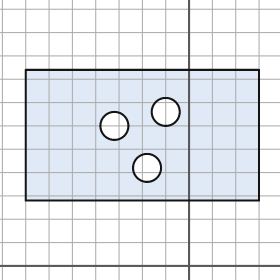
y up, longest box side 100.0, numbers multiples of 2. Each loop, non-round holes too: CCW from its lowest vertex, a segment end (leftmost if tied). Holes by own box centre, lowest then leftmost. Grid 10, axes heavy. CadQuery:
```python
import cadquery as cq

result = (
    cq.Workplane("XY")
    .moveTo(-70.0, 28.0)
    .lineTo(30.0, 28.0)
    .lineTo(30.0, 84.0)
    .lineTo(-70.0, 84.0)
    .close()
    .moveTo(-18.0, 42.0)
    .circle(6.0)
    .moveTo(-32.0, 60.0)
    .circle(6.0)
    .moveTo(-10.0, 66.0)
    .circle(6.0)
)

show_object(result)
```